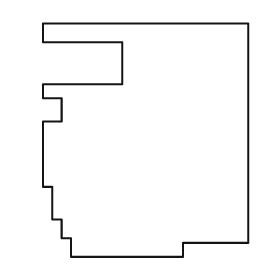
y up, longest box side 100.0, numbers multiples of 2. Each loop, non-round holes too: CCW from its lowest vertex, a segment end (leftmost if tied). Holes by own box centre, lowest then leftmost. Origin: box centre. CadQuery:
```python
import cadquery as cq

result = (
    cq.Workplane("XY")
    .moveTo(-32.0, -50.0)
    .lineTo(16.0, -50.0)
    .lineTo(16.0, -44.0)
    .lineTo(44.0, -44.0)
    .lineTo(44.0, 50.0)
    .lineTo(-44.0, 50.0)
    .lineTo(-44.0, 42.0)
    .lineTo(-10.0, 42.0)
    .lineTo(-10.0, 24.0)
    .lineTo(-44.0, 24.0)
    .lineTo(-44.0, 18.0)
    .lineTo(-36.0, 18.0)
    .lineTo(-36.0, 8.0)
    .lineTo(-44.0, 8.0)
    .lineTo(-44.0, -20.0)
    .lineTo(-40.0, -20.0)
    .lineTo(-40.0, -34.0)
    .lineTo(-36.0, -34.0)
    .lineTo(-36.0, -42.0)
    .lineTo(-32.0, -42.0)
    .close()
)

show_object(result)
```